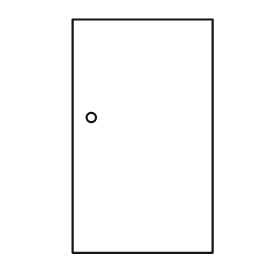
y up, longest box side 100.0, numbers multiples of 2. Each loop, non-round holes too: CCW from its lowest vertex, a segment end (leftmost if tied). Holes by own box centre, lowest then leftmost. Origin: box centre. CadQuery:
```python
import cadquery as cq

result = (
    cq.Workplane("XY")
    .moveTo(-30.0, -50.0)
    .lineTo(30.0, -50.0)
    .lineTo(30.0, 50.0)
    .lineTo(-30.0, 50.0)
    .close()
    .moveTo(-22.0, 8.0)
    .circle(2.0)
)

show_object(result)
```